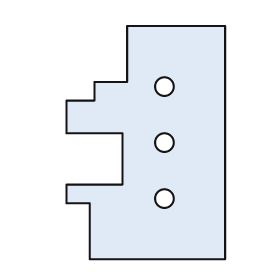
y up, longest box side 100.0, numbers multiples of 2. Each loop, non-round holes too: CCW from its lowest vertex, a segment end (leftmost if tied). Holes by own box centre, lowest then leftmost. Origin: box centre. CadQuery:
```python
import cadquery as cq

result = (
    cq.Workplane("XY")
    .moveTo(-24.0, -50.0)
    .lineTo(34.0, -50.0)
    .lineTo(34.0, 50.0)
    .lineTo(-8.0, 50.0)
    .lineTo(-8.0, 26.0)
    .lineTo(-22.0, 26.0)
    .lineTo(-22.0, 18.0)
    .lineTo(-34.0, 18.0)
    .lineTo(-34.0, 4.0)
    .lineTo(-10.0, 4.0)
    .lineTo(-10.0, -18.0)
    .lineTo(-34.0, -18.0)
    .lineTo(-34.0, -26.0)
    .lineTo(-24.0, -26.0)
    .close()
    .moveTo(8.0, -24.0)
    .circle(4.0)
    .moveTo(8.0, 0.0)
    .circle(4.0)
    .moveTo(8.0, 24.0)
    .circle(4.0)
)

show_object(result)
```